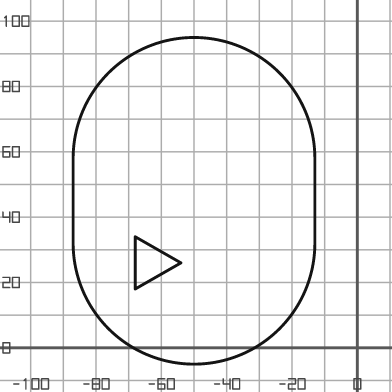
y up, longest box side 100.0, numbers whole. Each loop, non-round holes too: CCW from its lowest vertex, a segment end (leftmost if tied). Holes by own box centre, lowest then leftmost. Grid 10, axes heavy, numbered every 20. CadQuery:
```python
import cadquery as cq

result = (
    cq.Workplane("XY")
    .moveTo(-87.0, 32.0)
    .threePointArc((-50.0, -5.0), (-13.0, 32.0))
    .lineTo(-13.0, 58.0)
    .threePointArc((-50.0, 95.0), (-87.0, 58.0))
    .close()
    .moveTo(-68.0, 18.0)
    .lineTo(-54.0, 26.0)
    .lineTo(-68.0, 34.0)
    .close()
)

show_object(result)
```